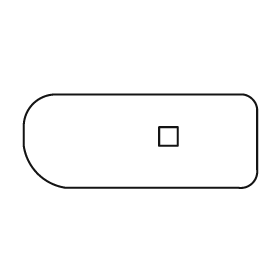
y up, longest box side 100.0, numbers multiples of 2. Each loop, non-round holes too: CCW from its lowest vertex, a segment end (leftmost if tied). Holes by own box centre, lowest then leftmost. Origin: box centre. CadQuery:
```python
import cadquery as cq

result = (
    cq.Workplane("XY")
    .moveTo(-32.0, -20.0)
    .lineTo(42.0, -20.0)
    .threePointArc((48.0, -18.0), (50.0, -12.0))
    .lineTo(50.0, 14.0)
    .threePointArc((48.0, 18.0), (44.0, 20.0))
    .lineTo(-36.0, 20.0)
    .threePointArc((-46.0, 16.0), (-50.0, 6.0))
    .lineTo(-50.0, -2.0)
    .threePointArc((-44.0, -14.0), (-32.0, -20.0))
    .close()
    .moveTo(8.0, -2.0)
    .lineTo(16.0, -2.0)
    .lineTo(16.0, 6.0)
    .lineTo(8.0, 6.0)
    .close()
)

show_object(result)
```